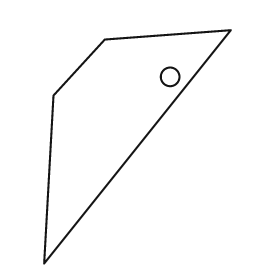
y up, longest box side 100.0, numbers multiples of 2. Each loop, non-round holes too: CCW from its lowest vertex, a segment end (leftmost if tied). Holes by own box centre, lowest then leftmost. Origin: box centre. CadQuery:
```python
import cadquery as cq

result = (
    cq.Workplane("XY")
    .moveTo(-40.0, -50.0)
    .lineTo(40.0, 50.0)
    .lineTo(-14.0, 46.0)
    .lineTo(-36.0, 22.0)
    .close()
    .moveTo(14.0, 30.0)
    .circle(4.0)
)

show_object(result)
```